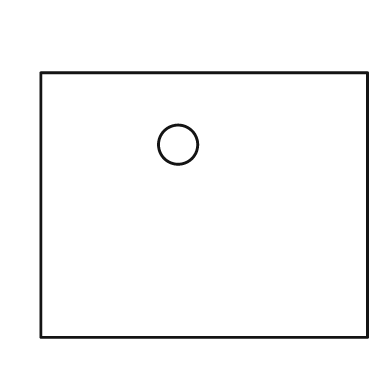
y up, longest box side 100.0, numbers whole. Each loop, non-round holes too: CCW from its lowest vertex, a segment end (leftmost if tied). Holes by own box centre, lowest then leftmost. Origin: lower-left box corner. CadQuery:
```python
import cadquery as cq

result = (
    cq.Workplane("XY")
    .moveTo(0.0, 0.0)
    .lineTo(100.0, 0.0)
    .lineTo(100.0, 81.0)
    .lineTo(0.0, 81.0)
    .close()
    .moveTo(42.0, 59.0)
    .circle(6.0)
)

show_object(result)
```